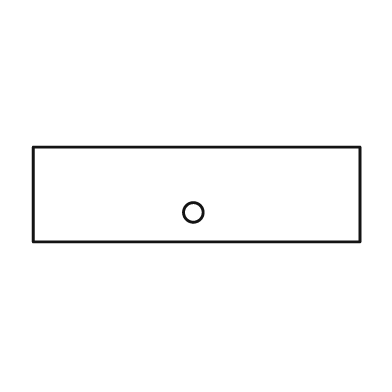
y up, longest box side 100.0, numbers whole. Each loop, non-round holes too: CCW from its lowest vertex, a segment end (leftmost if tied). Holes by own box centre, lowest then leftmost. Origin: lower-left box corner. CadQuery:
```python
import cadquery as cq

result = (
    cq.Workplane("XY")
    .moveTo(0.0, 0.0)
    .lineTo(100.0, 0.0)
    .lineTo(100.0, 29.0)
    .lineTo(0.0, 29.0)
    .close()
    .moveTo(49.0, 9.0)
    .circle(3.0)
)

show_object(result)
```